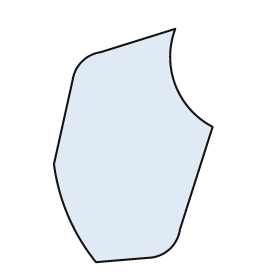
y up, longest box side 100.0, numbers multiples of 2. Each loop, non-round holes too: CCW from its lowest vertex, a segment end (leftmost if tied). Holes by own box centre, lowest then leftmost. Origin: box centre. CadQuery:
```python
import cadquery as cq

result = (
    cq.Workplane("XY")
    .moveTo(-16.0, -50.0)
    .lineTo(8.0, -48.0)
    .threePointArc((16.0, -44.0), (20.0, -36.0))
    .lineTo(34.0, 8.0)
    .threePointArc((18.0, 26.0), (18.0, 50.0))
    .lineTo(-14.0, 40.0)
    .threePointArc((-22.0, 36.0), (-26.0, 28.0))
    .lineTo(-34.0, -8.0)
    .threePointArc((-28.0, -30.0), (-16.0, -50.0))
    .close()
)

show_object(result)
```